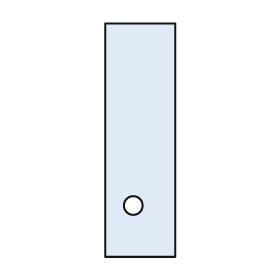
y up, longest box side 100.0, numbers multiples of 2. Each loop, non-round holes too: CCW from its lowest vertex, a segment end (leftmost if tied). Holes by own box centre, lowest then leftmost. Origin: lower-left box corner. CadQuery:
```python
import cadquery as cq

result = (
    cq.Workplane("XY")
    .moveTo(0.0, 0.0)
    .lineTo(30.0, 0.0)
    .lineTo(30.0, 100.0)
    .lineTo(0.0, 100.0)
    .close()
    .moveTo(12.0, 22.0)
    .circle(4.0)
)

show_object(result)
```